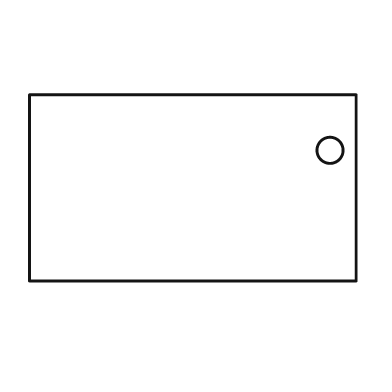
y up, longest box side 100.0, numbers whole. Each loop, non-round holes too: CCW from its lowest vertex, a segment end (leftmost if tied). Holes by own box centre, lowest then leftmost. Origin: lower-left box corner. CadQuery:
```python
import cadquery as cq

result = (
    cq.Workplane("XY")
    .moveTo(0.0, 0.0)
    .lineTo(100.0, 0.0)
    .lineTo(100.0, 57.0)
    .lineTo(0.0, 57.0)
    .close()
    .moveTo(92.0, 40.0)
    .circle(4.0)
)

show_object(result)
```